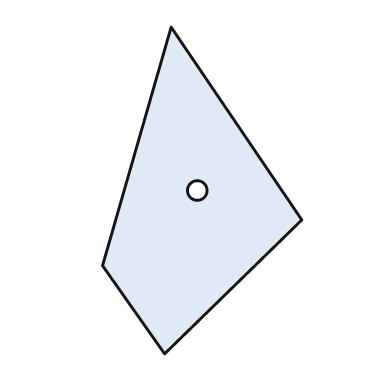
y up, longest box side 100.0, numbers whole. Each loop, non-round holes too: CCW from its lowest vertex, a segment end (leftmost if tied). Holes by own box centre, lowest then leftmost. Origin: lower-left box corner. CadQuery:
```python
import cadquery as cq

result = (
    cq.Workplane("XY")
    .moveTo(19.0, 0.0)
    .lineTo(61.0, 41.0)
    .lineTo(21.0, 100.0)
    .lineTo(0.0, 27.0)
    .close()
    .moveTo(29.0, 50.0)
    .circle(3.0)
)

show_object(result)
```